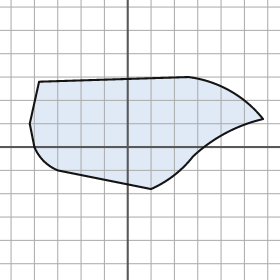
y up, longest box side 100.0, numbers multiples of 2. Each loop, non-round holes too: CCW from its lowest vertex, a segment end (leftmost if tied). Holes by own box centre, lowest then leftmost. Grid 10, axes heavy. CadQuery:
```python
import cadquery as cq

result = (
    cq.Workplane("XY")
    .moveTo(10.0, -18.0)
    .threePointArc((20.0, -12.0), (28.0, -4.0))
    .threePointArc((42.0, 6.0), (58.0, 12.0))
    .threePointArc((44.0, 24.0), (26.0, 30.0))
    .lineTo(-38.0, 28.0)
    .lineTo(-42.0, 10.0)
    .lineTo(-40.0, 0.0)
    .threePointArc((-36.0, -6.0), (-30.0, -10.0))
    .close()
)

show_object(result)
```